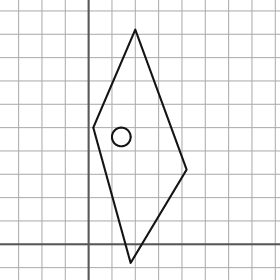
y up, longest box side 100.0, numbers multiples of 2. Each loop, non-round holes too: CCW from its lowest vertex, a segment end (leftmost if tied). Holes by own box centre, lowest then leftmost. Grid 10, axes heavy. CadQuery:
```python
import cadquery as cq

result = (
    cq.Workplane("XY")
    .moveTo(18.0, -8.0)
    .lineTo(42.0, 32.0)
    .lineTo(20.0, 92.0)
    .lineTo(2.0, 50.0)
    .close()
    .moveTo(14.0, 46.0)
    .circle(4.0)
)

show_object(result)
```